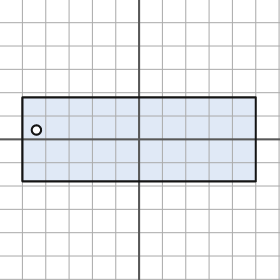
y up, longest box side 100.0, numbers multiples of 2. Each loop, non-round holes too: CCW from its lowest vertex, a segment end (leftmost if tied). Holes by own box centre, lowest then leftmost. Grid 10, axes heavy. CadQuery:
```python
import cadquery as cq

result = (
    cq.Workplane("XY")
    .moveTo(-50.0, -18.0)
    .lineTo(50.0, -18.0)
    .lineTo(50.0, 18.0)
    .lineTo(-50.0, 18.0)
    .close()
    .moveTo(-44.0, 4.0)
    .circle(2.0)
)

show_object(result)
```